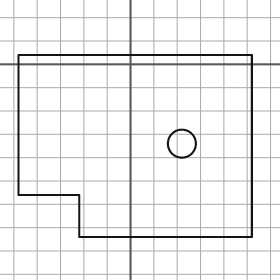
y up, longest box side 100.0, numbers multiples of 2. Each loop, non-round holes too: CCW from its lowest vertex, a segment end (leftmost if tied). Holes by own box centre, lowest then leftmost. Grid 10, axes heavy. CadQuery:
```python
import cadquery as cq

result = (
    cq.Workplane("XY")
    .moveTo(-22.0, -74.0)
    .lineTo(52.0, -74.0)
    .lineTo(52.0, 4.0)
    .lineTo(-48.0, 4.0)
    .lineTo(-48.0, -56.0)
    .lineTo(-22.0, -56.0)
    .close()
    .moveTo(22.0, -34.0)
    .circle(6.0)
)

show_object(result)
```